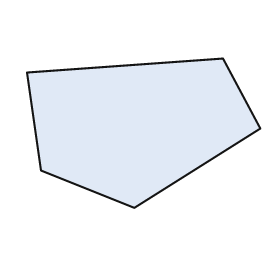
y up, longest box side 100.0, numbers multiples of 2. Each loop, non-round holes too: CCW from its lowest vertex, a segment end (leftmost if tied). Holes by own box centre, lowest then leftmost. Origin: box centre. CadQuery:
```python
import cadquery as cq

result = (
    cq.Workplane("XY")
    .moveTo(-4.0, -32.0)
    .lineTo(50.0, 2.0)
    .lineTo(34.0, 32.0)
    .lineTo(-50.0, 26.0)
    .lineTo(-44.0, -16.0)
    .close()
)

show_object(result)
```